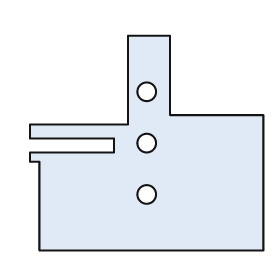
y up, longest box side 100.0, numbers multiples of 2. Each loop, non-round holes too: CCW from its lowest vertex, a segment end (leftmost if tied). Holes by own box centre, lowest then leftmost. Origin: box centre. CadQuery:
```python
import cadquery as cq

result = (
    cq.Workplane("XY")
    .moveTo(-46.0, -46.0)
    .lineTo(50.0, -46.0)
    .lineTo(50.0, 12.0)
    .lineTo(10.0, 12.0)
    .lineTo(10.0, 46.0)
    .lineTo(-8.0, 46.0)
    .lineTo(-8.0, 8.0)
    .lineTo(-50.0, 8.0)
    .lineTo(-50.0, 2.0)
    .lineTo(-14.0, 2.0)
    .lineTo(-14.0, -4.0)
    .lineTo(-50.0, -4.0)
    .lineTo(-50.0, -8.0)
    .lineTo(-46.0, -8.0)
    .close()
    .moveTo(0.0, -22.0)
    .circle(4.0)
    .moveTo(0.0, 0.0)
    .circle(4.0)
    .moveTo(0.0, 22.0)
    .circle(4.0)
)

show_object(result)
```